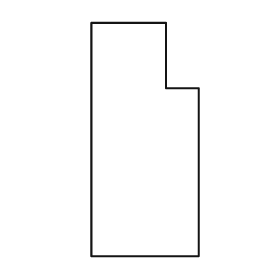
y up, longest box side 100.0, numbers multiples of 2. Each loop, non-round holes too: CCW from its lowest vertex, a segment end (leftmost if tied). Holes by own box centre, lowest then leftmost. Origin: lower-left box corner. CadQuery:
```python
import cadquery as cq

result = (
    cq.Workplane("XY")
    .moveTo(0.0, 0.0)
    .lineTo(46.0, 0.0)
    .lineTo(46.0, 72.0)
    .lineTo(32.0, 72.0)
    .lineTo(32.0, 100.0)
    .lineTo(0.0, 100.0)
    .close()
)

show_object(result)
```